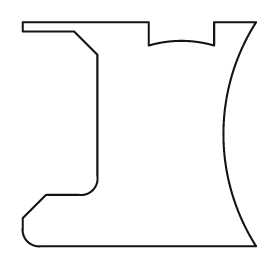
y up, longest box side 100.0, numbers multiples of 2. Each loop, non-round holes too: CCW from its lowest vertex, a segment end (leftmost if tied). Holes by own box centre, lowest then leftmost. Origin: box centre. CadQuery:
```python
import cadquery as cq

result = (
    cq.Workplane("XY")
    .moveTo(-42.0, -48.0)
    .lineTo(50.0, -48.0)
    .threePointArc((36.0, 0.0), (50.0, 48.0))
    .lineTo(32.0, 48.0)
    .lineTo(32.0, 38.0)
    .threePointArc((18.0, 40.0), (4.0, 38.0))
    .lineTo(4.0, 48.0)
    .lineTo(-50.0, 48.0)
    .lineTo(-50.0, 44.0)
    .lineTo(-28.0, 44.0)
    .lineTo(-18.0, 34.0)
    .lineTo(-18.0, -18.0)
    .threePointArc((-20.0, -24.0), (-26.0, -26.0))
    .lineTo(-40.0, -26.0)
    .lineTo(-50.0, -36.0)
    .lineTo(-50.0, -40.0)
    .threePointArc((-48.0, -46.0), (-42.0, -48.0))
    .close()
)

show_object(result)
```